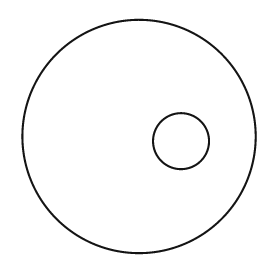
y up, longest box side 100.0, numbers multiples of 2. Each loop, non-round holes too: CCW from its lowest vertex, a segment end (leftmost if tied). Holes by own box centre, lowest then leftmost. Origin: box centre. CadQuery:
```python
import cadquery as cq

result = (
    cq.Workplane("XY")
    .moveTo(0.0, 0.0)
    .circle(50.0)
    .moveTo(18.0, -2.0)
    .circle(12.0)
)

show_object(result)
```